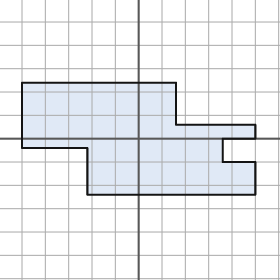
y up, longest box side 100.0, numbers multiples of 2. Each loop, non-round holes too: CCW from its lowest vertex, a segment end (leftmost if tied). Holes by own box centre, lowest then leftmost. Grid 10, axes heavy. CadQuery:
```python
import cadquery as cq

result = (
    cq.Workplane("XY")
    .moveTo(-22.0, -24.0)
    .lineTo(50.0, -24.0)
    .lineTo(50.0, -10.0)
    .lineTo(36.0, -10.0)
    .lineTo(36.0, 0.0)
    .lineTo(50.0, 0.0)
    .lineTo(50.0, 6.0)
    .lineTo(16.0, 6.0)
    .lineTo(16.0, 24.0)
    .lineTo(-50.0, 24.0)
    .lineTo(-50.0, -4.0)
    .lineTo(-22.0, -4.0)
    .close()
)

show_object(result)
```